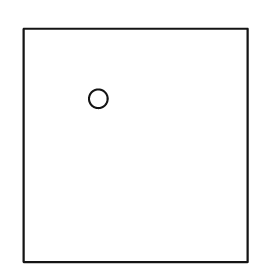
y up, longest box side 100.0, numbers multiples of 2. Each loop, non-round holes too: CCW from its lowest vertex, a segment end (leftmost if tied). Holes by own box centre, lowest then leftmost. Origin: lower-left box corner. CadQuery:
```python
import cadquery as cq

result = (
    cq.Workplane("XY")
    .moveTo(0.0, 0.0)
    .lineTo(96.0, 0.0)
    .lineTo(96.0, 100.0)
    .lineTo(0.0, 100.0)
    .close()
    .moveTo(32.0, 70.0)
    .circle(4.0)
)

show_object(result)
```